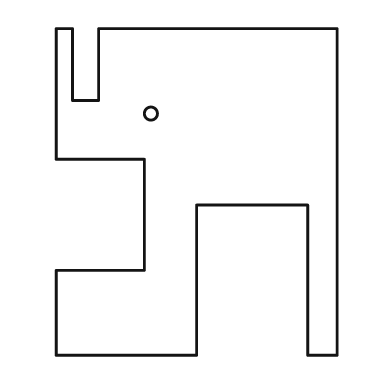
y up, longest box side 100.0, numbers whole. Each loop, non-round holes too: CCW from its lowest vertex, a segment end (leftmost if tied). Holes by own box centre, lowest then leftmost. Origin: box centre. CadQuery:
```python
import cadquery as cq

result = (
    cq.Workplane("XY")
    .moveTo(-43.0, -50.0)
    .lineTo(0.0, -50.0)
    .lineTo(0.0, -4.0)
    .lineTo(34.0, -4.0)
    .lineTo(34.0, -50.0)
    .lineTo(43.0, -50.0)
    .lineTo(43.0, 50.0)
    .lineTo(-30.0, 50.0)
    .lineTo(-30.0, 28.0)
    .lineTo(-38.0, 28.0)
    .lineTo(-38.0, 50.0)
    .lineTo(-43.0, 50.0)
    .lineTo(-43.0, 10.0)
    .lineTo(-16.0, 10.0)
    .lineTo(-16.0, -24.0)
    .lineTo(-43.0, -24.0)
    .close()
    .moveTo(-14.0, 24.0)
    .circle(2.0)
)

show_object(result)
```